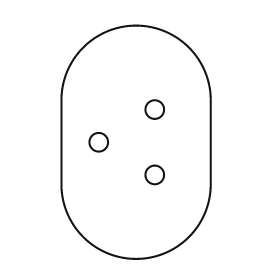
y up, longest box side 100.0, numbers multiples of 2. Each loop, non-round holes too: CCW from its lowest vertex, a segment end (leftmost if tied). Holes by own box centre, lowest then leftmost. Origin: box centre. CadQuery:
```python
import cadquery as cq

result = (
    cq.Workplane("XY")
    .moveTo(-32.0, -18.0)
    .threePointArc((0.0, -50.0), (32.0, -18.0))
    .lineTo(32.0, 18.0)
    .threePointArc((0.0, 50.0), (-32.0, 18.0))
    .close()
    .moveTo(8.0, -14.0)
    .circle(4.0)
    .moveTo(-16.0, 0.0)
    .circle(4.0)
    .moveTo(8.0, 14.0)
    .circle(4.0)
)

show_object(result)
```